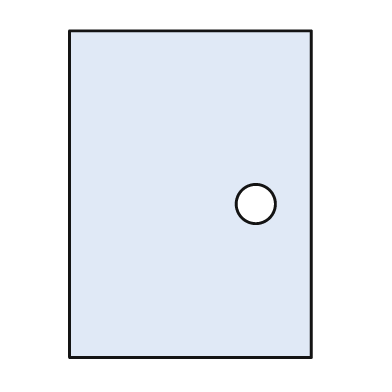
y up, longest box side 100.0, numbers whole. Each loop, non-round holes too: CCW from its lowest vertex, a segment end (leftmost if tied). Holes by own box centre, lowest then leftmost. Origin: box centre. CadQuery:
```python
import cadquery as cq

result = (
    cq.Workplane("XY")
    .moveTo(-37.0, -50.0)
    .lineTo(37.0, -50.0)
    .lineTo(37.0, 50.0)
    .lineTo(-37.0, 50.0)
    .close()
    .moveTo(20.0, -3.0)
    .circle(6.0)
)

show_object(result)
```